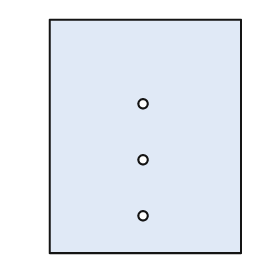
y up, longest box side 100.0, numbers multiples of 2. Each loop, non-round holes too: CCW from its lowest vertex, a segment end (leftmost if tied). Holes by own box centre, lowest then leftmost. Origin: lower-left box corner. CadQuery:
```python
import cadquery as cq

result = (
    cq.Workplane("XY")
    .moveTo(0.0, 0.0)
    .lineTo(82.0, 0.0)
    .lineTo(82.0, 100.0)
    .lineTo(0.0, 100.0)
    .close()
    .moveTo(40.0, 16.0)
    .circle(2.0)
    .moveTo(40.0, 40.0)
    .circle(2.0)
    .moveTo(40.0, 64.0)
    .circle(2.0)
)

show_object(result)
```